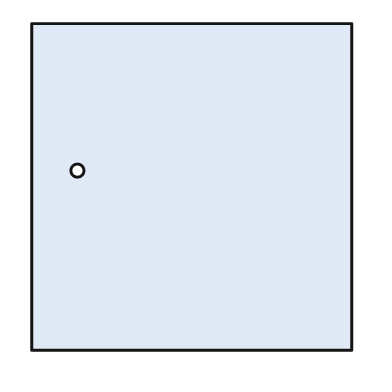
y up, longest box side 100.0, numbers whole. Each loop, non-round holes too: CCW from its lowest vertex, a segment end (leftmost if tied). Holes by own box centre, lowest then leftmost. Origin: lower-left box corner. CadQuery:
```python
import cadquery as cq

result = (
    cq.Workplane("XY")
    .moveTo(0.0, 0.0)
    .lineTo(98.0, 0.0)
    .lineTo(98.0, 100.0)
    .lineTo(0.0, 100.0)
    .close()
    .moveTo(14.0, 55.0)
    .circle(2.0)
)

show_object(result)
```